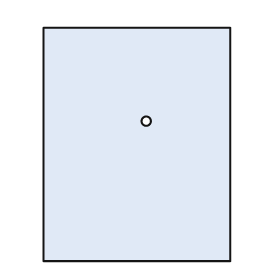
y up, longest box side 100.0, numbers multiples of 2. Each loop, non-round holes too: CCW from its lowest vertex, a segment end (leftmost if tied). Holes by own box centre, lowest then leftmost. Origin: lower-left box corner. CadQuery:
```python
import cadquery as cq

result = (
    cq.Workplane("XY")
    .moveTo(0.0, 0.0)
    .lineTo(80.0, 0.0)
    .lineTo(80.0, 100.0)
    .lineTo(0.0, 100.0)
    .close()
    .moveTo(44.0, 60.0)
    .circle(2.0)
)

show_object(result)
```